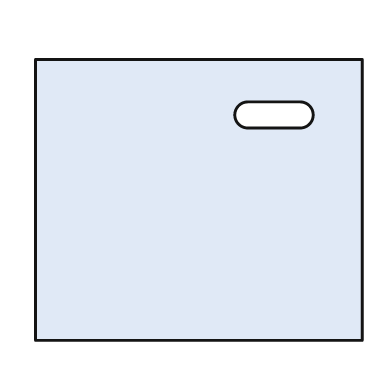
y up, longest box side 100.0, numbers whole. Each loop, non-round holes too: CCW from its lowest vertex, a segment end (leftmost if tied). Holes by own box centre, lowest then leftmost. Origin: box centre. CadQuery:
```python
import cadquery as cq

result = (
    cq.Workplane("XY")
    .moveTo(-50.0, -43.0)
    .lineTo(50.0, -43.0)
    .lineTo(50.0, 43.0)
    .lineTo(-50.0, 43.0)
    .close()
    .moveTo(15.0, 22.0)
    .lineTo(31.0, 22.0)
    .threePointArc((35.0, 26.0), (31.0, 30.0))
    .lineTo(15.0, 30.0)
    .threePointArc((11.0, 26.0), (15.0, 22.0))
    .close()
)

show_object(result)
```